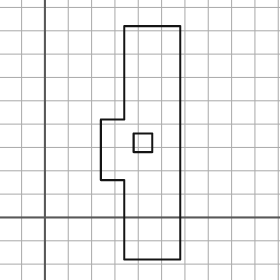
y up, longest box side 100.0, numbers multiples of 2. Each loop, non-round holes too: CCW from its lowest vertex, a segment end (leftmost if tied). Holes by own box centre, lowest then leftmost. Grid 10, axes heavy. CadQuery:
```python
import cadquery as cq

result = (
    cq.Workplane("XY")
    .moveTo(34.0, -18.0)
    .lineTo(58.0, -18.0)
    .lineTo(58.0, 82.0)
    .lineTo(34.0, 82.0)
    .lineTo(34.0, 42.0)
    .lineTo(24.0, 42.0)
    .lineTo(24.0, 16.0)
    .lineTo(34.0, 16.0)
    .close()
    .moveTo(38.0, 28.0)
    .lineTo(46.0, 28.0)
    .lineTo(46.0, 36.0)
    .lineTo(38.0, 36.0)
    .close()
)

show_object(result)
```